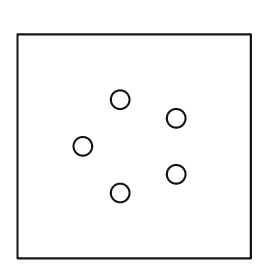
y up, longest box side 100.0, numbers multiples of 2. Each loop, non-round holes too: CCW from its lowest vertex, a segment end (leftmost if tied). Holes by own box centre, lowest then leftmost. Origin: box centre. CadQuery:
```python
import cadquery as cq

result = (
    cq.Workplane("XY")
    .moveTo(-50.0, -48.0)
    .lineTo(50.0, -48.0)
    .lineTo(50.0, 48.0)
    .lineTo(-50.0, 48.0)
    .close()
    .moveTo(-6.0, -20.0)
    .circle(4.0)
    .moveTo(18.0, -12.0)
    .circle(4.0)
    .moveTo(-22.0, 0.0)
    .circle(4.0)
    .moveTo(18.0, 12.0)
    .circle(4.0)
    .moveTo(-6.0, 20.0)
    .circle(4.0)
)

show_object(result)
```